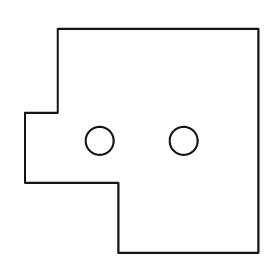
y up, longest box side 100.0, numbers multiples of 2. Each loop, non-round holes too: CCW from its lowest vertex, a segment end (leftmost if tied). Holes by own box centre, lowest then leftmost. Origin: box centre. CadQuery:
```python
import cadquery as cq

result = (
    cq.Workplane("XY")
    .moveTo(-10.0, -48.0)
    .lineTo(50.0, -48.0)
    .lineTo(50.0, 48.0)
    .lineTo(-36.0, 48.0)
    .lineTo(-36.0, 12.0)
    .lineTo(-50.0, 12.0)
    .lineTo(-50.0, -18.0)
    .lineTo(-10.0, -18.0)
    .close()
    .moveTo(-18.0, 0.0)
    .circle(6.0)
    .moveTo(18.0, 0.0)
    .circle(6.0)
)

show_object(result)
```